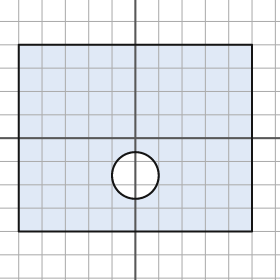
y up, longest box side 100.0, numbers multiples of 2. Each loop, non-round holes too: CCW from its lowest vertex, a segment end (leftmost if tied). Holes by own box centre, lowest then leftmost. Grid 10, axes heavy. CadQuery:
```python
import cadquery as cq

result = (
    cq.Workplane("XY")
    .moveTo(-50.0, -40.0)
    .lineTo(50.0, -40.0)
    .lineTo(50.0, 40.0)
    .lineTo(-50.0, 40.0)
    .close()
    .moveTo(0.0, -16.0)
    .circle(10.0)
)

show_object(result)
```